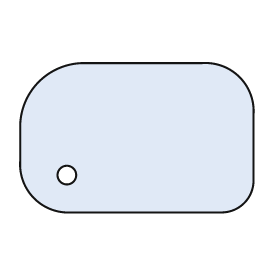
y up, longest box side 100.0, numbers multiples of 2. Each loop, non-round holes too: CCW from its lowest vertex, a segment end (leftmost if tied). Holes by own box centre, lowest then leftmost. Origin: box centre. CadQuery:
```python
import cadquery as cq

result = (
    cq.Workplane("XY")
    .moveTo(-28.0, -32.0)
    .lineTo(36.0, -32.0)
    .threePointArc((46.0, -28.0), (50.0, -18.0))
    .lineTo(50.0, 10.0)
    .threePointArc((44.0, 26.0), (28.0, 32.0))
    .lineTo(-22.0, 32.0)
    .threePointArc((-42.0, 24.0), (-50.0, 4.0))
    .lineTo(-50.0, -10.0)
    .threePointArc((-44.0, -26.0), (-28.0, -32.0))
    .close()
    .moveTo(-30.0, -16.0)
    .circle(4.0)
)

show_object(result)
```